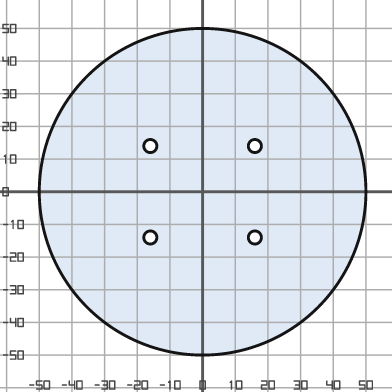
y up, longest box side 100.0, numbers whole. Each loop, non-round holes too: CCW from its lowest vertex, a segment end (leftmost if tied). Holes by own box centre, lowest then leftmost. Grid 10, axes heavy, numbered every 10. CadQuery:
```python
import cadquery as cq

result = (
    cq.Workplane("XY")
    .moveTo(0.0, 0.0)
    .circle(50.0)
    .moveTo(-16.0, -14.0)
    .circle(2.0)
    .moveTo(16.0, -14.0)
    .circle(2.0)
    .moveTo(-16.0, 14.0)
    .circle(2.0)
    .moveTo(16.0, 14.0)
    .circle(2.0)
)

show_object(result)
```